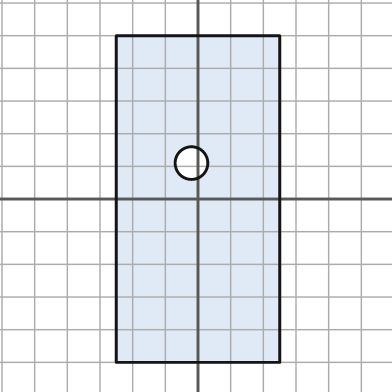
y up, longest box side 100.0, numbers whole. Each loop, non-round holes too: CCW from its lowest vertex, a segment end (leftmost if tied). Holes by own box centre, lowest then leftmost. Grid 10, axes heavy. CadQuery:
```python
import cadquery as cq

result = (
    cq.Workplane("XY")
    .moveTo(-25.0, -50.0)
    .lineTo(25.0, -50.0)
    .lineTo(25.0, 50.0)
    .lineTo(-25.0, 50.0)
    .close()
    .moveTo(-2.0, 11.0)
    .circle(5.0)
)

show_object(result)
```